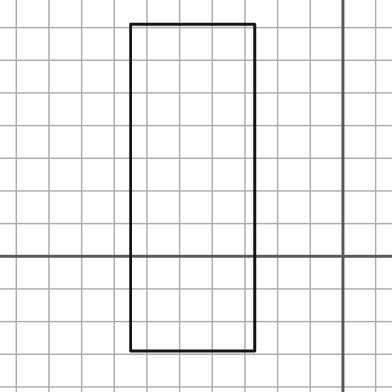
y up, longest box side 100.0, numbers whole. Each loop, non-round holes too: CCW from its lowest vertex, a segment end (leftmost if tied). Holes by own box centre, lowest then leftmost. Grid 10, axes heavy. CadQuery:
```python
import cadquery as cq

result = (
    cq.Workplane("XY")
    .moveTo(-65.0, -29.0)
    .lineTo(-27.0, -29.0)
    .lineTo(-27.0, 71.0)
    .lineTo(-65.0, 71.0)
    .close()
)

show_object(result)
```